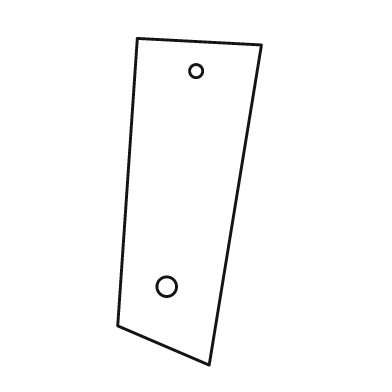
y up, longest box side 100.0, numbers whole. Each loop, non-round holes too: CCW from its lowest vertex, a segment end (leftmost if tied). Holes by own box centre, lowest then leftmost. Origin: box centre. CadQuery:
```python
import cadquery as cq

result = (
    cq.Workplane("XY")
    .moveTo(6.0, -50.0)
    .lineTo(22.0, 48.0)
    .lineTo(-16.0, 50.0)
    .lineTo(-22.0, -38.0)
    .close()
    .moveTo(-7.0, -26.0)
    .circle(3.0)
    .moveTo(2.0, 40.0)
    .circle(2.0)
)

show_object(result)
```